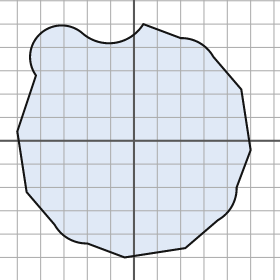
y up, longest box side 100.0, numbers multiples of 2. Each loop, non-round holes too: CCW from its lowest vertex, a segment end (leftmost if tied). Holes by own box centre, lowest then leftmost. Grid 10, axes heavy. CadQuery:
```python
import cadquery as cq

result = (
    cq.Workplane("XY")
    .moveTo(-4.0, -50.0)
    .lineTo(22.0, -46.0)
    .lineTo(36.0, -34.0)
    .threePointArc((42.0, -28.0), (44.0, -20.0))
    .lineTo(50.0, -4.0)
    .lineTo(46.0, 22.0)
    .lineTo(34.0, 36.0)
    .threePointArc((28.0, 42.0), (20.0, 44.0))
    .lineTo(4.0, 50.0)
    .threePointArc((-8.0, 42.0), (-22.0, 46.0))
    .threePointArc((-40.0, 46.0), (-42.0, 28.0))
    .lineTo(-50.0, 4.0)
    .lineTo(-46.0, -22.0)
    .lineTo(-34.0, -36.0)
    .threePointArc((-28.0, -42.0), (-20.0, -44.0))
    .close()
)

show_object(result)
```